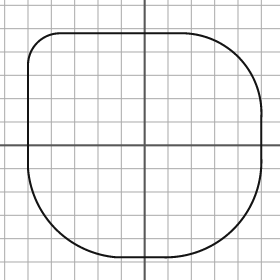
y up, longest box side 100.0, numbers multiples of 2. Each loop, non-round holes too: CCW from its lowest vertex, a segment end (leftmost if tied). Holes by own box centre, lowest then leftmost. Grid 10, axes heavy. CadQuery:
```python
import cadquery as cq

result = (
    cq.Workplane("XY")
    .moveTo(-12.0, -48.0)
    .lineTo(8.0, -48.0)
    .threePointArc((38.0, -36.0), (50.0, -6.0))
    .lineTo(50.0, 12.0)
    .threePointArc((40.0, 38.0), (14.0, 48.0))
    .lineTo(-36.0, 48.0)
    .threePointArc((-46.0, 44.0), (-50.0, 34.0))
    .lineTo(-50.0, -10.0)
    .threePointArc((-38.0, -36.0), (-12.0, -48.0))
    .close()
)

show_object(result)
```